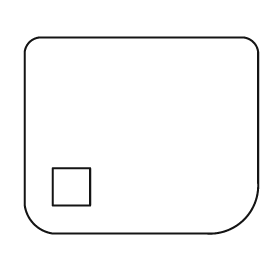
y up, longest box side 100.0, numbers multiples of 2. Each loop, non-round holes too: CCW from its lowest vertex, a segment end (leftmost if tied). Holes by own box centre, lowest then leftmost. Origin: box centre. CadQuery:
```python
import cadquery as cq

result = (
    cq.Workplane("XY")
    .moveTo(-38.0, -42.0)
    .lineTo(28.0, -42.0)
    .threePointArc((44.0, -36.0), (50.0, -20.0))
    .lineTo(50.0, 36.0)
    .threePointArc((48.0, 40.0), (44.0, 42.0))
    .lineTo(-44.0, 42.0)
    .threePointArc((-48.0, 40.0), (-50.0, 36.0))
    .lineTo(-50.0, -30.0)
    .threePointArc((-46.0, -38.0), (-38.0, -42.0))
    .close()
    .moveTo(-38.0, -30.0)
    .lineTo(-22.0, -30.0)
    .lineTo(-22.0, -14.0)
    .lineTo(-38.0, -14.0)
    .close()
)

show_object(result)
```